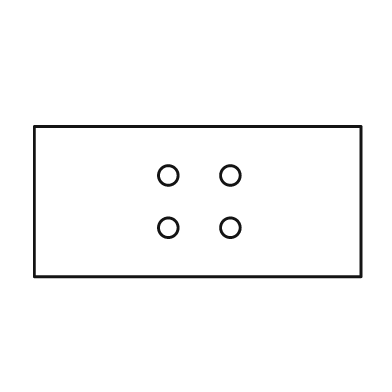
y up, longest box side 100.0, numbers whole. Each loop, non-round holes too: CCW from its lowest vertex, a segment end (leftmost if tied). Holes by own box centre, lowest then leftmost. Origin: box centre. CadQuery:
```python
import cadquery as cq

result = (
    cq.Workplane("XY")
    .moveTo(-50.0, -23.0)
    .lineTo(50.0, -23.0)
    .lineTo(50.0, 23.0)
    .lineTo(-50.0, 23.0)
    .close()
    .moveTo(-9.0, -8.0)
    .circle(3.0)
    .moveTo(10.0, -8.0)
    .circle(3.0)
    .moveTo(-9.0, 8.0)
    .circle(3.0)
    .moveTo(10.0, 8.0)
    .circle(3.0)
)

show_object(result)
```